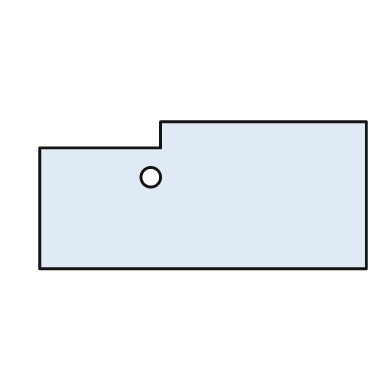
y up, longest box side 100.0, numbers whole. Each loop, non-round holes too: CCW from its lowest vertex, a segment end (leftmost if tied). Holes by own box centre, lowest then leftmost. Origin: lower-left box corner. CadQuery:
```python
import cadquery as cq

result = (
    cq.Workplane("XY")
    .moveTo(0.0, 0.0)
    .lineTo(100.0, 0.0)
    .lineTo(100.0, 45.0)
    .lineTo(37.0, 45.0)
    .lineTo(37.0, 37.0)
    .lineTo(0.0, 37.0)
    .close()
    .moveTo(34.0, 28.0)
    .circle(3.0)
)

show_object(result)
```